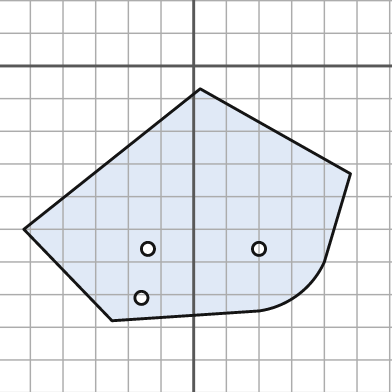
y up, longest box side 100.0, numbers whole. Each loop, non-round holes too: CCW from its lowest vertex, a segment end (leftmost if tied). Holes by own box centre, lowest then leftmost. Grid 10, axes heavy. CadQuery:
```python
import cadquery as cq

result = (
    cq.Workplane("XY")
    .moveTo(-25.0, -78.0)
    .lineTo(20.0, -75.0)
    .threePointArc((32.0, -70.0), (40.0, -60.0))
    .lineTo(48.0, -33.0)
    .lineTo(2.0, -7.0)
    .lineTo(-52.0, -50.0)
    .close()
    .moveTo(-16.0, -71.0)
    .circle(2.0)
    .moveTo(-14.0, -56.0)
    .circle(2.0)
    .moveTo(20.0, -56.0)
    .circle(2.0)
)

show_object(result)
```